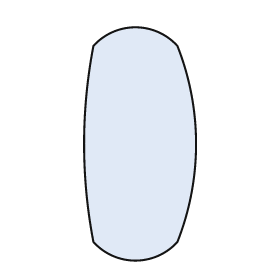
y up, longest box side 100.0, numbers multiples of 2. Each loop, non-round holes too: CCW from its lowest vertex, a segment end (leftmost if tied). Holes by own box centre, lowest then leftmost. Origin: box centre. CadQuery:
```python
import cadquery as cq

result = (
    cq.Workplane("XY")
    .moveTo(-20.0, -42.0)
    .threePointArc((-2.0, -50.0), (16.0, -42.0))
    .threePointArc((24.0, 0.0), (16.0, 42.0))
    .threePointArc((-2.0, 50.0), (-20.0, 42.0))
    .threePointArc((-24.0, 0.0), (-20.0, -42.0))
    .close()
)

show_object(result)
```